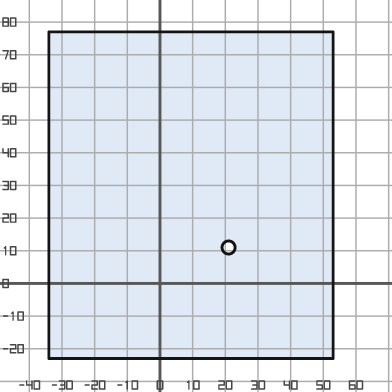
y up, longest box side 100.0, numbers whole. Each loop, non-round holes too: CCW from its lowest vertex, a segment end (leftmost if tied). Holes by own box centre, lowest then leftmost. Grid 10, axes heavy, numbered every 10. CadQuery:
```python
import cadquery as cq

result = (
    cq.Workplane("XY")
    .moveTo(-34.0, -23.0)
    .lineTo(53.0, -23.0)
    .lineTo(53.0, 77.0)
    .lineTo(-34.0, 77.0)
    .close()
    .moveTo(21.0, 11.0)
    .circle(2.0)
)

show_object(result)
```